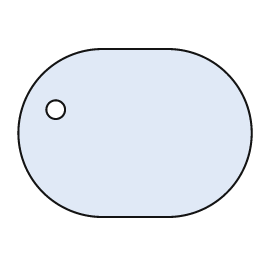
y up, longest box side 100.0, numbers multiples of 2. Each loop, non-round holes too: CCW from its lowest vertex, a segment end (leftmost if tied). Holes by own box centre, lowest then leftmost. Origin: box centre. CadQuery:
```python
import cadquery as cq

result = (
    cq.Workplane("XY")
    .moveTo(-14.0, -36.0)
    .lineTo(14.0, -36.0)
    .threePointArc((50.0, 0.0), (14.0, 36.0))
    .lineTo(-14.0, 36.0)
    .threePointArc((-50.0, 0.0), (-14.0, -36.0))
    .close()
    .moveTo(-34.0, 10.0)
    .circle(4.0)
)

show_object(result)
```